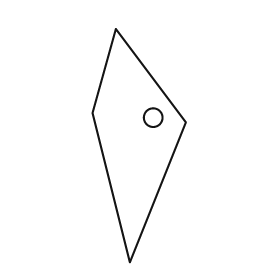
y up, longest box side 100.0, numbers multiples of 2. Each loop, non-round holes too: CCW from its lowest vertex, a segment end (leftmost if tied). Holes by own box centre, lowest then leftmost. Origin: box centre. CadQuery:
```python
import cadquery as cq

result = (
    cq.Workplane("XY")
    .moveTo(-4.0, -50.0)
    .lineTo(20.0, 10.0)
    .lineTo(-10.0, 50.0)
    .lineTo(-20.0, 14.0)
    .close()
    .moveTo(6.0, 12.0)
    .circle(4.0)
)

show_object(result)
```